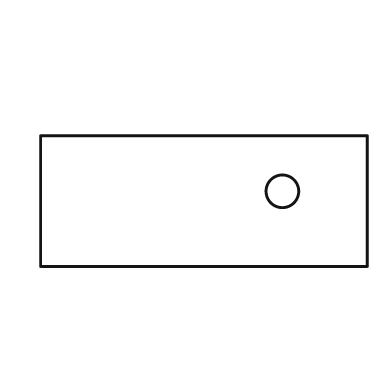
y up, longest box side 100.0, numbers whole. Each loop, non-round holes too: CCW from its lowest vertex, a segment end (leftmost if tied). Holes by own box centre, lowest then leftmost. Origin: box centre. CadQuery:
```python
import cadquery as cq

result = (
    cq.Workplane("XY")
    .moveTo(-50.0, -20.0)
    .lineTo(50.0, -20.0)
    .lineTo(50.0, 20.0)
    .lineTo(-50.0, 20.0)
    .close()
    .moveTo(24.0, 3.0)
    .circle(5.0)
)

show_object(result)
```